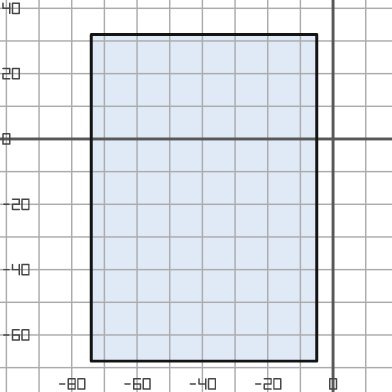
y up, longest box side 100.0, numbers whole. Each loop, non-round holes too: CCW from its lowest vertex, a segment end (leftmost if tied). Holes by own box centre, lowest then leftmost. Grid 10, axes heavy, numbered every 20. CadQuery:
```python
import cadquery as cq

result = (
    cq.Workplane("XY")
    .moveTo(-74.0, -68.0)
    .lineTo(-5.0, -68.0)
    .lineTo(-5.0, 32.0)
    .lineTo(-74.0, 32.0)
    .close()
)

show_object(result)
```